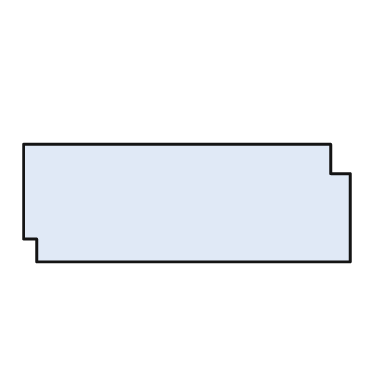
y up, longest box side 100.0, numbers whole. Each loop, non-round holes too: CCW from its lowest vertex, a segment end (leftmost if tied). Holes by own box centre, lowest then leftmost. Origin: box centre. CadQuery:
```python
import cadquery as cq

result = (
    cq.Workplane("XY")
    .moveTo(-46.0, -18.0)
    .lineTo(50.0, -18.0)
    .lineTo(50.0, 9.0)
    .lineTo(44.0, 9.0)
    .lineTo(44.0, 18.0)
    .lineTo(-50.0, 18.0)
    .lineTo(-50.0, -11.0)
    .lineTo(-46.0, -11.0)
    .close()
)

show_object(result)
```